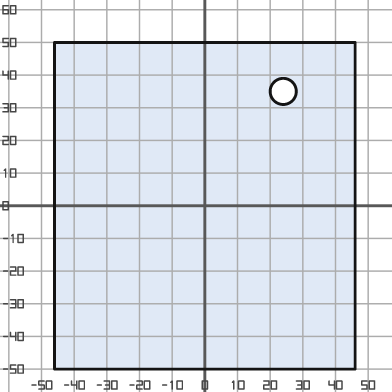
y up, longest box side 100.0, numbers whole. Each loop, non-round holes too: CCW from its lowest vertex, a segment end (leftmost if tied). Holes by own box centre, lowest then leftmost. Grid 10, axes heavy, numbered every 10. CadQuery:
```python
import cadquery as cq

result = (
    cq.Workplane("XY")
    .moveTo(-46.0, -50.0)
    .lineTo(46.0, -50.0)
    .lineTo(46.0, 50.0)
    .lineTo(-46.0, 50.0)
    .close()
    .moveTo(24.0, 35.0)
    .circle(4.0)
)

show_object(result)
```